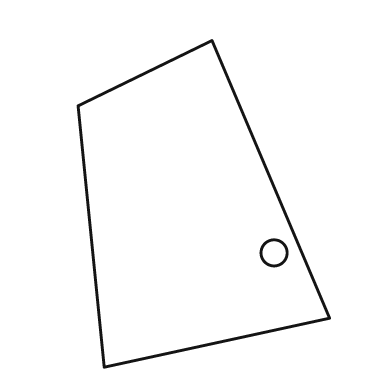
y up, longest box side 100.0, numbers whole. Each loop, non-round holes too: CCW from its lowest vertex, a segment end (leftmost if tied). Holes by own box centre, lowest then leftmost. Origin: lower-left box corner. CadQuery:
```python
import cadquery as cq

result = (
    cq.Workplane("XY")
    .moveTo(8.0, 0.0)
    .lineTo(77.0, 15.0)
    .lineTo(41.0, 100.0)
    .lineTo(0.0, 80.0)
    .close()
    .moveTo(60.0, 35.0)
    .circle(4.0)
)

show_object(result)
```